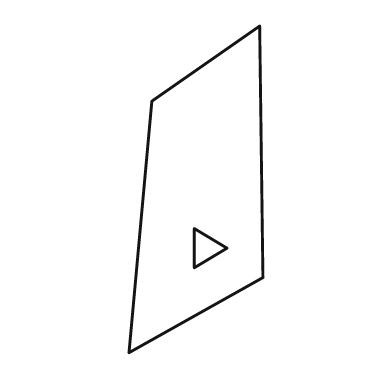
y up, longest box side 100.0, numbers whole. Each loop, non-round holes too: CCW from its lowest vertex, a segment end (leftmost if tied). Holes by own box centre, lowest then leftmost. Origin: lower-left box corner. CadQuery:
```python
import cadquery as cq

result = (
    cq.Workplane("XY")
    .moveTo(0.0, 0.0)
    .lineTo(41.0, 23.0)
    .lineTo(40.0, 100.0)
    .lineTo(7.0, 77.0)
    .close()
    .moveTo(20.0, 26.0)
    .lineTo(30.0, 32.0)
    .lineTo(20.0, 38.0)
    .close()
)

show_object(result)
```